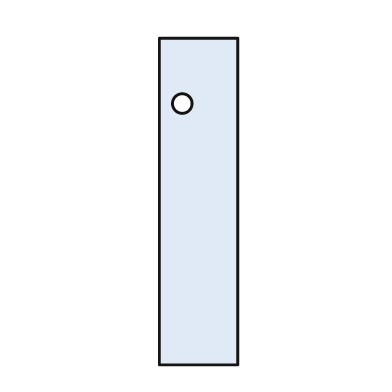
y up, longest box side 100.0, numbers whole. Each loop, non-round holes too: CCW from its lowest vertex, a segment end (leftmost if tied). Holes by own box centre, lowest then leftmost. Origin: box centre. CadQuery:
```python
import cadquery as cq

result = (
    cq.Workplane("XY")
    .moveTo(-12.0, -50.0)
    .lineTo(12.0, -50.0)
    .lineTo(12.0, 50.0)
    .lineTo(-12.0, 50.0)
    .close()
    .moveTo(-5.0, 30.0)
    .circle(3.0)
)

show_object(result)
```